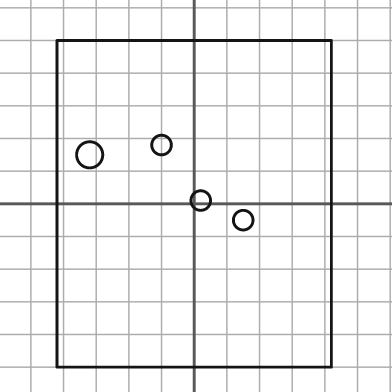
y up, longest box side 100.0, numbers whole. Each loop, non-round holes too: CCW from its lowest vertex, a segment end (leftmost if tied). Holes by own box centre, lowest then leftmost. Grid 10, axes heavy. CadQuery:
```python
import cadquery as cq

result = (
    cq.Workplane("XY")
    .moveTo(-42.0, -50.0)
    .lineTo(42.0, -50.0)
    .lineTo(42.0, 50.0)
    .lineTo(-42.0, 50.0)
    .close()
    .moveTo(15.0, -5.0)
    .circle(3.0)
    .moveTo(2.0, 1.0)
    .circle(3.0)
    .moveTo(-32.0, 15.0)
    .circle(4.0)
    .moveTo(-10.0, 18.0)
    .circle(3.0)
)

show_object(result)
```